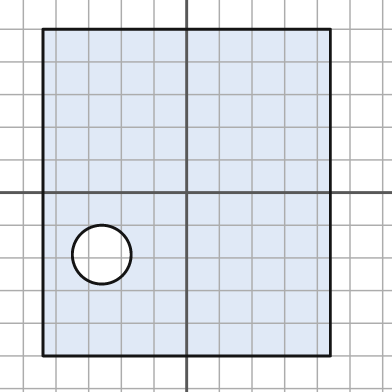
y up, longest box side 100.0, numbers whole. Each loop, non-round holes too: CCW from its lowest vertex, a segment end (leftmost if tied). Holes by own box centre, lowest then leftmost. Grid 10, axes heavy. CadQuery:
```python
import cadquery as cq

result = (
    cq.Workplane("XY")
    .moveTo(-44.0, -50.0)
    .lineTo(44.0, -50.0)
    .lineTo(44.0, 50.0)
    .lineTo(-44.0, 50.0)
    .close()
    .moveTo(-26.0, -19.0)
    .circle(9.0)
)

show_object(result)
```